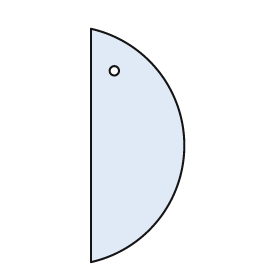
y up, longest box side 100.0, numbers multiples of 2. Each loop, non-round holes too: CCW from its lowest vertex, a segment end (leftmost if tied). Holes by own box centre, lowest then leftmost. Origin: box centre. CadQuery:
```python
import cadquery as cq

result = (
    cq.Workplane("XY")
    .moveTo(-20.0, -50.0)
    .threePointArc((20.0, 0.0), (-20.0, 50.0))
    .close()
    .moveTo(-10.0, 32.0)
    .circle(2.0)
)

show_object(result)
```